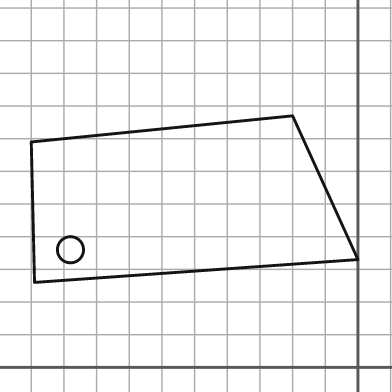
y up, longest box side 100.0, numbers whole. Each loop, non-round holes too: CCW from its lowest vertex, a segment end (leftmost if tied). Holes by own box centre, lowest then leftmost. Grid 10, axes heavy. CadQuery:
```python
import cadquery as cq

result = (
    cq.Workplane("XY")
    .moveTo(-99.0, 26.0)
    .lineTo(0.0, 33.0)
    .lineTo(-20.0, 77.0)
    .lineTo(-100.0, 69.0)
    .close()
    .moveTo(-88.0, 36.0)
    .circle(4.0)
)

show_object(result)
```